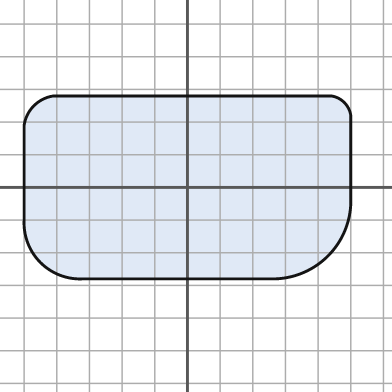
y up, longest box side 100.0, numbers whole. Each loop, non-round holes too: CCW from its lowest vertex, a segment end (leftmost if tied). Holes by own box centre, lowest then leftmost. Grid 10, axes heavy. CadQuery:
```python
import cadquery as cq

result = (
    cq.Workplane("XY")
    .moveTo(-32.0, -28.0)
    .lineTo(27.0, -28.0)
    .threePointArc((43.0, -21.0), (50.0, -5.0))
    .lineTo(50.0, 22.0)
    .threePointArc((48.0, 26.0), (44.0, 28.0))
    .lineTo(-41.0, 28.0)
    .threePointArc((-47.0, 25.0), (-50.0, 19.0))
    .lineTo(-50.0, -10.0)
    .threePointArc((-45.0, -23.0), (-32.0, -28.0))
    .close()
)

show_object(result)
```